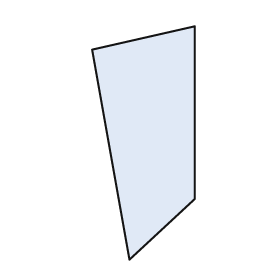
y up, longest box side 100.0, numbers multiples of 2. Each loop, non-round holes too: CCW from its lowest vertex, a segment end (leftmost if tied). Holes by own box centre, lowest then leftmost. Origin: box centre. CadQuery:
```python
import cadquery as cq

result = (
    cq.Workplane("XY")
    .moveTo(-6.0, -50.0)
    .lineTo(22.0, -24.0)
    .lineTo(22.0, 50.0)
    .lineTo(-22.0, 40.0)
    .close()
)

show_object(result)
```